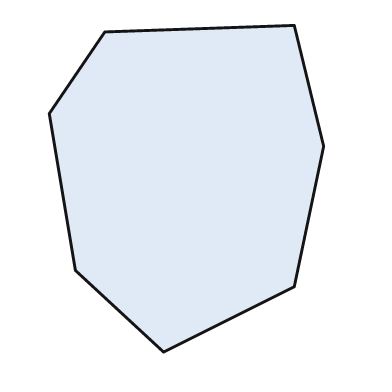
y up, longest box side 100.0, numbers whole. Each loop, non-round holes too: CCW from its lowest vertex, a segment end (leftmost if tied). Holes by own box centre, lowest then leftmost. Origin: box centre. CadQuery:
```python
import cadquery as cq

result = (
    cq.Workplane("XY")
    .moveTo(-7.0, -50.0)
    .lineTo(33.0, -30.0)
    .lineTo(42.0, 13.0)
    .lineTo(33.0, 50.0)
    .lineTo(-25.0, 48.0)
    .lineTo(-42.0, 23.0)
    .lineTo(-34.0, -25.0)
    .close()
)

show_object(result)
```